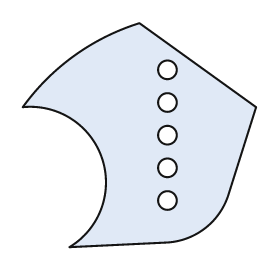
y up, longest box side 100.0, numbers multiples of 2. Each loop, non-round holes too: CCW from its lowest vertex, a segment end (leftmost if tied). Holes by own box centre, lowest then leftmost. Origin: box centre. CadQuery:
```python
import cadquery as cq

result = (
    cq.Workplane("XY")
    .moveTo(-30.0, -48.0)
    .lineTo(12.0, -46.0)
    .threePointArc((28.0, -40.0), (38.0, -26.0))
    .lineTo(50.0, 12.0)
    .lineTo(0.0, 48.0)
    .threePointArc((-28.0, 34.0), (-50.0, 12.0))
    .threePointArc((-16.0, -10.0), (-30.0, -48.0))
    .close()
    .moveTo(12.0, -28.0)
    .circle(4.0)
    .moveTo(12.0, -14.0)
    .circle(4.0)
    .moveTo(12.0, 0.0)
    .circle(4.0)
    .moveTo(12.0, 14.0)
    .circle(4.0)
    .moveTo(12.0, 28.0)
    .circle(4.0)
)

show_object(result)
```